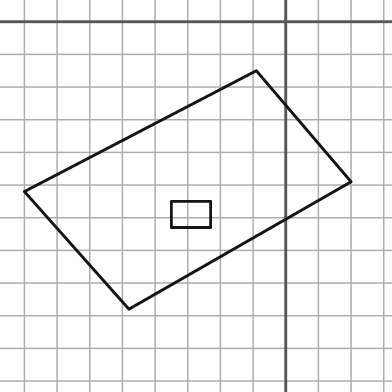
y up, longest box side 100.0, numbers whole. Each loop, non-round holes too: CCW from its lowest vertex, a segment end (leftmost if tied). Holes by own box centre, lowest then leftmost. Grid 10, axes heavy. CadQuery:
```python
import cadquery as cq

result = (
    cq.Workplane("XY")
    .moveTo(-48.0, -88.0)
    .lineTo(20.0, -49.0)
    .lineTo(-9.0, -15.0)
    .lineTo(-80.0, -52.0)
    .close()
    .moveTo(-35.0, -63.0)
    .lineTo(-23.0, -63.0)
    .lineTo(-23.0, -55.0)
    .lineTo(-35.0, -55.0)
    .close()
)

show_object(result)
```